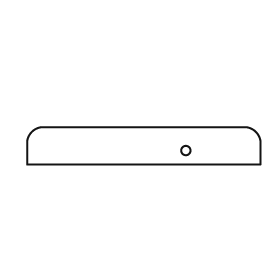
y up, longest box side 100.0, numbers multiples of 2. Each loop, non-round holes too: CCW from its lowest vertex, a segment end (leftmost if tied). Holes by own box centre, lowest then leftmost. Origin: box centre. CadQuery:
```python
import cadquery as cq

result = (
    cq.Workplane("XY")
    .moveTo(-50.0, -8.0)
    .lineTo(50.0, -8.0)
    .lineTo(50.0, 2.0)
    .threePointArc((48.0, 6.0), (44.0, 8.0))
    .lineTo(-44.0, 8.0)
    .threePointArc((-48.0, 6.0), (-50.0, 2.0))
    .close()
    .moveTo(18.0, -2.0)
    .circle(2.0)
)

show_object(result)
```